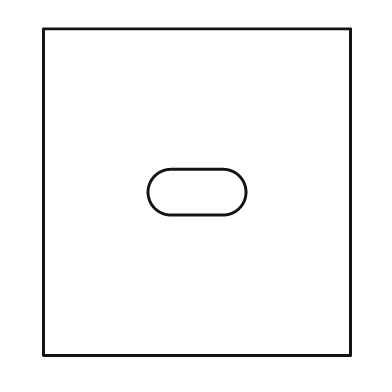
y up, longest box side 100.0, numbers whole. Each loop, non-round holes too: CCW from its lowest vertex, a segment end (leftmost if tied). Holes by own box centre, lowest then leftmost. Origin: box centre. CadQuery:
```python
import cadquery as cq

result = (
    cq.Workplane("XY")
    .moveTo(-47.0, -50.0)
    .lineTo(47.0, -50.0)
    .lineTo(47.0, 50.0)
    .lineTo(-47.0, 50.0)
    .close()
    .moveTo(-8.0, -7.0)
    .lineTo(8.0, -7.0)
    .threePointArc((15.0, 0.0), (8.0, 7.0))
    .lineTo(-8.0, 7.0)
    .threePointArc((-15.0, 0.0), (-8.0, -7.0))
    .close()
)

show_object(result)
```